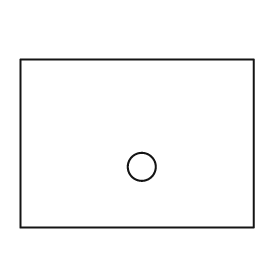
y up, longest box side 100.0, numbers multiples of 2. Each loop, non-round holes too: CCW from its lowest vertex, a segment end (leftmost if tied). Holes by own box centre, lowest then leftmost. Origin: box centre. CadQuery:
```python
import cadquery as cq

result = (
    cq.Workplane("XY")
    .moveTo(-50.0, -36.0)
    .lineTo(50.0, -36.0)
    .lineTo(50.0, 36.0)
    .lineTo(-50.0, 36.0)
    .close()
    .moveTo(2.0, -10.0)
    .circle(6.0)
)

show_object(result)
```